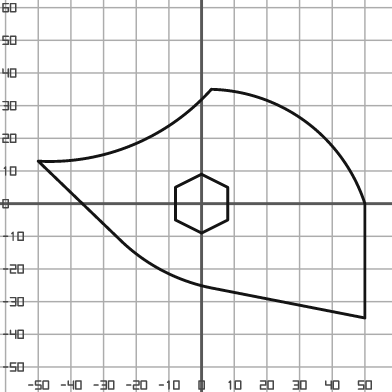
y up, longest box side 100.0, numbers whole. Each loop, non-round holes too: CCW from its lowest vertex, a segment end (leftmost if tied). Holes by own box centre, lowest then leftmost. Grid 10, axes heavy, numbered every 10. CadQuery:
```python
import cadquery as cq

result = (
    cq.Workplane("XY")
    .moveTo(50.0, -35.0)
    .lineTo(50.0, 0.0)
    .threePointArc((32.0, 25.0), (3.0, 35.0))
    .threePointArc((-21.0, 18.0), (-50.0, 13.0))
    .lineTo(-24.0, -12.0)
    .threePointArc((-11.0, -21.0), (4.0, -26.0))
    .close()
    .moveTo(0.0, -9.0)
    .lineTo(8.0, -5.0)
    .lineTo(8.0, 5.0)
    .lineTo(0.0, 9.0)
    .lineTo(-8.0, 5.0)
    .lineTo(-8.0, -5.0)
    .close()
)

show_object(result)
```